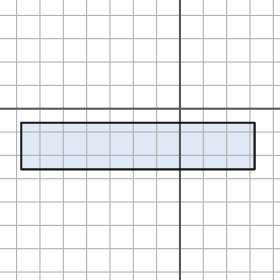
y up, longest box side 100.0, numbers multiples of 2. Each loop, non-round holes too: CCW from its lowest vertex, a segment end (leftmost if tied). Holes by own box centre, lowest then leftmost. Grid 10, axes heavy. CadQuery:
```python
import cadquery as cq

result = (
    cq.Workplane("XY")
    .moveTo(-68.0, -26.0)
    .lineTo(32.0, -26.0)
    .lineTo(32.0, -6.0)
    .lineTo(-68.0, -6.0)
    .close()
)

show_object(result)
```